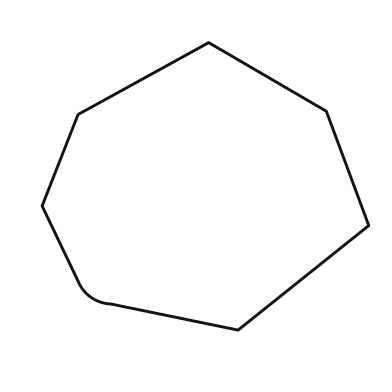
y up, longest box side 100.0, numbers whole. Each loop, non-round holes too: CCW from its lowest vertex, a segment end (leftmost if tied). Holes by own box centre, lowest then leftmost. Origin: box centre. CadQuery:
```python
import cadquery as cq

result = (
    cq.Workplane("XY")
    .moveTo(10.0, -44.0)
    .lineTo(50.0, -12.0)
    .lineTo(37.0, 23.0)
    .lineTo(1.0, 44.0)
    .lineTo(-39.0, 22.0)
    .lineTo(-50.0, -6.0)
    .lineTo(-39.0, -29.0)
    .threePointArc((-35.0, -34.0), (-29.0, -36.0))
    .close()
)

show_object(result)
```